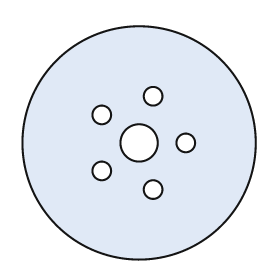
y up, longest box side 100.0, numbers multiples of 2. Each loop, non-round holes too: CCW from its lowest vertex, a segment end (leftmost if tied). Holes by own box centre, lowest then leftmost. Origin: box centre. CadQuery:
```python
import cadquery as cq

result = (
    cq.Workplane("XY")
    .moveTo(0.0, 0.0)
    .circle(50.0)
    .moveTo(6.0, -20.0)
    .circle(4.0)
    .moveTo(-16.0, -12.0)
    .circle(4.0)
    .moveTo(0.0, 0.0)
    .circle(8.0)
    .moveTo(20.0, 0.0)
    .circle(4.0)
    .moveTo(-16.0, 12.0)
    .circle(4.0)
    .moveTo(6.0, 20.0)
    .circle(4.0)
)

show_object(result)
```